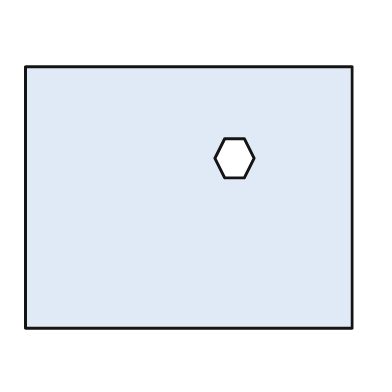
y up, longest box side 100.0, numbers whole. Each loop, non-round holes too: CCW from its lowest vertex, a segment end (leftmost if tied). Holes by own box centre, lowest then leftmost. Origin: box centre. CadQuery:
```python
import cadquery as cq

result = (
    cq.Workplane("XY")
    .moveTo(-50.0, -40.0)
    .lineTo(50.0, -40.0)
    .lineTo(50.0, 40.0)
    .lineTo(-50.0, 40.0)
    .close()
    .moveTo(11.0, 6.0)
    .lineTo(17.0, 6.0)
    .lineTo(20.0, 12.0)
    .lineTo(17.0, 18.0)
    .lineTo(11.0, 18.0)
    .lineTo(8.0, 12.0)
    .close()
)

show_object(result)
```